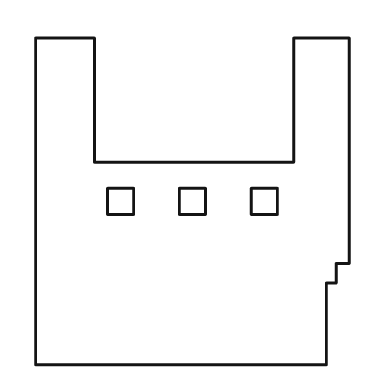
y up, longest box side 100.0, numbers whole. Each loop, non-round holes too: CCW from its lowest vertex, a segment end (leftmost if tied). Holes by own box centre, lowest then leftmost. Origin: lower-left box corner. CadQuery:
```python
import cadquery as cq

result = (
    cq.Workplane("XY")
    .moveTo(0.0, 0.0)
    .lineTo(89.0, 0.0)
    .lineTo(89.0, 25.0)
    .lineTo(92.0, 25.0)
    .lineTo(92.0, 31.0)
    .lineTo(96.0, 31.0)
    .lineTo(96.0, 100.0)
    .lineTo(79.0, 100.0)
    .lineTo(79.0, 62.0)
    .lineTo(18.0, 62.0)
    .lineTo(18.0, 100.0)
    .lineTo(0.0, 100.0)
    .close()
    .moveTo(22.0, 46.0)
    .lineTo(30.0, 46.0)
    .lineTo(30.0, 54.0)
    .lineTo(22.0, 54.0)
    .close()
    .moveTo(44.0, 46.0)
    .lineTo(52.0, 46.0)
    .lineTo(52.0, 54.0)
    .lineTo(44.0, 54.0)
    .close()
    .moveTo(66.0, 46.0)
    .lineTo(74.0, 46.0)
    .lineTo(74.0, 54.0)
    .lineTo(66.0, 54.0)
    .close()
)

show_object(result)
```